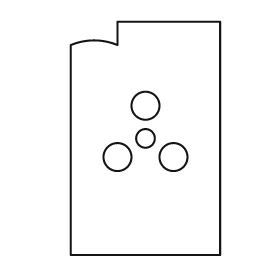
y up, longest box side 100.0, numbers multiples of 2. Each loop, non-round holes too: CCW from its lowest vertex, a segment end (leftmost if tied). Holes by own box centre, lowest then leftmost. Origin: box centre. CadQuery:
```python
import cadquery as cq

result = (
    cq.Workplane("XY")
    .moveTo(-32.0, -50.0)
    .lineTo(32.0, -50.0)
    .lineTo(32.0, 50.0)
    .lineTo(-12.0, 50.0)
    .lineTo(-12.0, 40.0)
    .threePointArc((-22.0, 42.0), (-32.0, 40.0))
    .close()
    .moveTo(-12.0, -8.0)
    .circle(6.0)
    .moveTo(12.0, -8.0)
    .circle(6.0)
    .moveTo(0.0, 0.0)
    .circle(4.0)
    .moveTo(0.0, 14.0)
    .circle(6.0)
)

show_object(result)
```